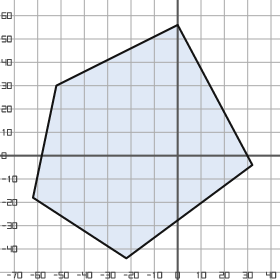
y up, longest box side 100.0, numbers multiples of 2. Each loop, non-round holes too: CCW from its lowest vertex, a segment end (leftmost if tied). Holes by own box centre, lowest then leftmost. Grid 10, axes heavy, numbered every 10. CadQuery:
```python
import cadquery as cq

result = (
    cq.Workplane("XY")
    .moveTo(-22.0, -44.0)
    .lineTo(32.0, -4.0)
    .lineTo(0.0, 56.0)
    .lineTo(-52.0, 30.0)
    .lineTo(-62.0, -18.0)
    .close()
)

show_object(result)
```